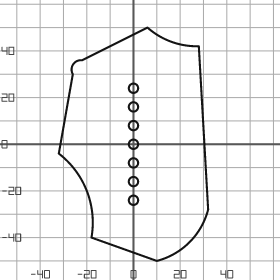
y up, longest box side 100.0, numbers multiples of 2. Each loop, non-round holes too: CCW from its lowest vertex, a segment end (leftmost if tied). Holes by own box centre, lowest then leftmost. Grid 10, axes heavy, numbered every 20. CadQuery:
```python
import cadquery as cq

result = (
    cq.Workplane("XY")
    .moveTo(10.0, -50.0)
    .threePointArc((24.0, -42.0), (32.0, -28.0))
    .lineTo(28.0, 42.0)
    .threePointArc((16.0, 44.0), (6.0, 50.0))
    .lineTo(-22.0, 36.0)
    .threePointArc((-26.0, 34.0), (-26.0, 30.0))
    .lineTo(-32.0, -4.0)
    .threePointArc((-20.0, -20.0), (-18.0, -40.0))
    .close()
    .moveTo(0.0, -24.0)
    .circle(2.0)
    .moveTo(0.0, -16.0)
    .circle(2.0)
    .moveTo(0.0, -8.0)
    .circle(2.0)
    .moveTo(0.0, 0.0)
    .circle(2.0)
    .moveTo(0.0, 8.0)
    .circle(2.0)
    .moveTo(0.0, 16.0)
    .circle(2.0)
    .moveTo(0.0, 24.0)
    .circle(2.0)
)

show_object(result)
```